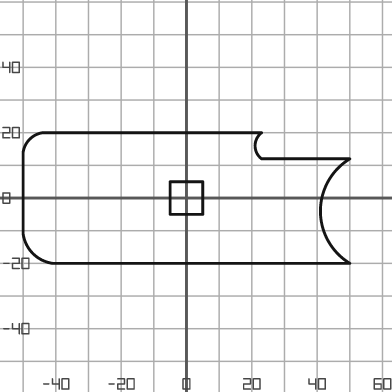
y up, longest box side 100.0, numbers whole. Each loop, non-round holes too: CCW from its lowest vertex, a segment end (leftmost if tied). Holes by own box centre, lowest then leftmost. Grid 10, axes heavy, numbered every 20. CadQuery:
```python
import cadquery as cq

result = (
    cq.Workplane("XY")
    .moveTo(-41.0, -20.0)
    .lineTo(50.0, -20.0)
    .threePointArc((41.0, -4.0), (50.0, 12.0))
    .lineTo(23.0, 12.0)
    .threePointArc((21.0, 16.0), (23.0, 20.0))
    .lineTo(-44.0, 20.0)
    .threePointArc((-48.0, 18.0), (-50.0, 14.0))
    .lineTo(-50.0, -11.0)
    .threePointArc((-47.0, -17.0), (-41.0, -20.0))
    .close()
    .moveTo(-5.0, -5.0)
    .lineTo(5.0, -5.0)
    .lineTo(5.0, 5.0)
    .lineTo(-5.0, 5.0)
    .close()
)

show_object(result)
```